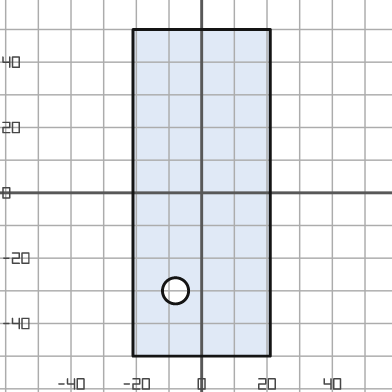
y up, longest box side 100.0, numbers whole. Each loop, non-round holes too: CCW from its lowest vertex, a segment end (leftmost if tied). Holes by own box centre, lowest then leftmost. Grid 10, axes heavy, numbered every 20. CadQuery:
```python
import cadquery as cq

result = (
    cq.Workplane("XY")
    .moveTo(-21.0, -50.0)
    .lineTo(21.0, -50.0)
    .lineTo(21.0, 50.0)
    .lineTo(-21.0, 50.0)
    .close()
    .moveTo(-8.0, -30.0)
    .circle(4.0)
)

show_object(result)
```